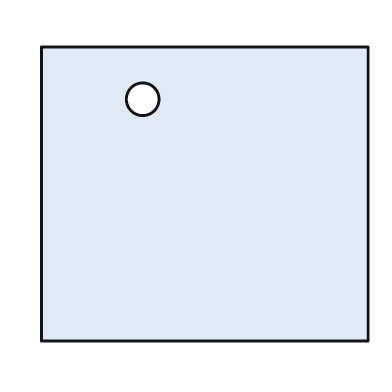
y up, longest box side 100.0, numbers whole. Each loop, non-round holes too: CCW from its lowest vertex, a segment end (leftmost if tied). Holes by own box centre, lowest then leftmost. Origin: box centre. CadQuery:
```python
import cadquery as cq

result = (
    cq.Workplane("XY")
    .moveTo(-50.0, -45.0)
    .lineTo(50.0, -45.0)
    .lineTo(50.0, 45.0)
    .lineTo(-50.0, 45.0)
    .close()
    .moveTo(-19.0, 29.0)
    .circle(5.0)
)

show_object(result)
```